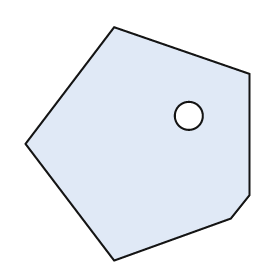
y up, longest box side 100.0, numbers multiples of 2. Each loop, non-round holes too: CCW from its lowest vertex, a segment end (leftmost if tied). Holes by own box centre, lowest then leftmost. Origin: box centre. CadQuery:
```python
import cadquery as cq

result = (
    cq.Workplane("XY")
    .moveTo(-10.0, -50.0)
    .lineTo(40.0, -32.0)
    .lineTo(48.0, -22.0)
    .lineTo(48.0, 30.0)
    .lineTo(-10.0, 50.0)
    .lineTo(-48.0, 0.0)
    .close()
    .moveTo(22.0, 12.0)
    .circle(6.0)
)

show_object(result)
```